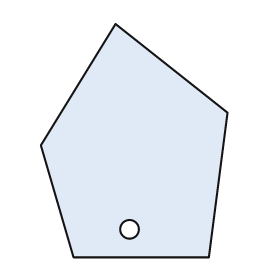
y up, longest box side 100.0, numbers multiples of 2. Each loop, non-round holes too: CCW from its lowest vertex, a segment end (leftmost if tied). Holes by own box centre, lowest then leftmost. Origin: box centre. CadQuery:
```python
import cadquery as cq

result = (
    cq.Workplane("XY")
    .moveTo(-26.0, -50.0)
    .lineTo(32.0, -50.0)
    .lineTo(40.0, 12.0)
    .lineTo(-8.0, 50.0)
    .lineTo(-40.0, -2.0)
    .close()
    .moveTo(-2.0, -38.0)
    .circle(4.0)
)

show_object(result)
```